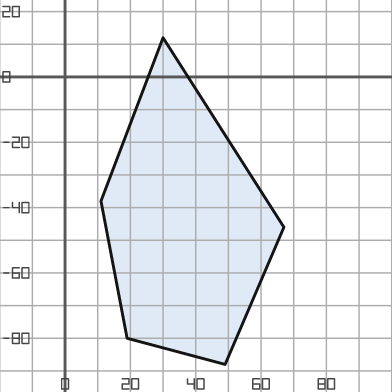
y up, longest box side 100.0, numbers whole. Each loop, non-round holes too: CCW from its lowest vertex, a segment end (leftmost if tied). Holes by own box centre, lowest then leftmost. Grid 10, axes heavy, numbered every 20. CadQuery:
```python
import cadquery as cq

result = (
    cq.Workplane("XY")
    .moveTo(49.0, -88.0)
    .lineTo(67.0, -46.0)
    .lineTo(30.0, 12.0)
    .lineTo(11.0, -38.0)
    .lineTo(19.0, -80.0)
    .close()
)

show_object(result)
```